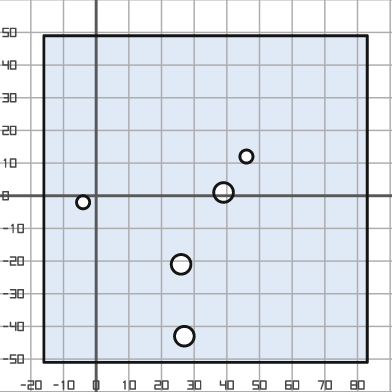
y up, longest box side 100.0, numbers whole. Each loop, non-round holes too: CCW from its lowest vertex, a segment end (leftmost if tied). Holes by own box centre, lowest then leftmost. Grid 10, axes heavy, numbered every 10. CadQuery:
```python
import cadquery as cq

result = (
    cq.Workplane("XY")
    .moveTo(-16.0, -51.0)
    .lineTo(83.0, -51.0)
    .lineTo(83.0, 49.0)
    .lineTo(-16.0, 49.0)
    .close()
    .moveTo(27.0, -43.0)
    .circle(3.0)
    .moveTo(26.0, -21.0)
    .circle(3.0)
    .moveTo(-4.0, -2.0)
    .circle(2.0)
    .moveTo(39.0, 1.0)
    .circle(3.0)
    .moveTo(46.0, 12.0)
    .circle(2.0)
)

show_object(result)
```